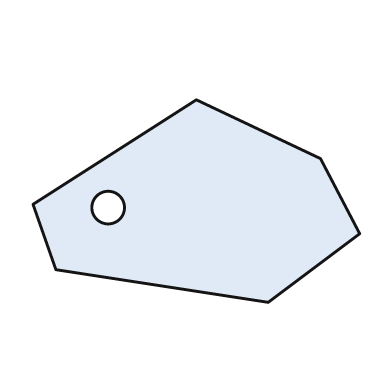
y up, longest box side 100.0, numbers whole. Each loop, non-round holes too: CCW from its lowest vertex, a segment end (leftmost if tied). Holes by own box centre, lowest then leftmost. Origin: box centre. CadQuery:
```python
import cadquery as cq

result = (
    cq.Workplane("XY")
    .moveTo(22.0, -31.0)
    .lineTo(50.0, -10.0)
    .lineTo(38.0, 13.0)
    .lineTo(0.0, 31.0)
    .lineTo(-50.0, -1.0)
    .lineTo(-43.0, -21.0)
    .close()
    .moveTo(-27.0, -2.0)
    .circle(5.0)
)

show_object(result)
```